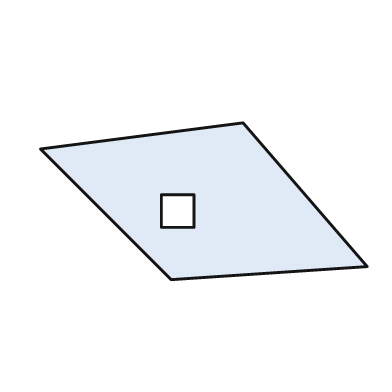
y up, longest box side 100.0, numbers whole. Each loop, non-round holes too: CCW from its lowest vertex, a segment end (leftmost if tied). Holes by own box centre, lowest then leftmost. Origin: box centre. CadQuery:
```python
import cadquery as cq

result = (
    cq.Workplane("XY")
    .moveTo(-10.0, -24.0)
    .lineTo(50.0, -20.0)
    .lineTo(12.0, 24.0)
    .lineTo(-50.0, 16.0)
    .close()
    .moveTo(-13.0, -8.0)
    .lineTo(-3.0, -8.0)
    .lineTo(-3.0, 2.0)
    .lineTo(-13.0, 2.0)
    .close()
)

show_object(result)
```